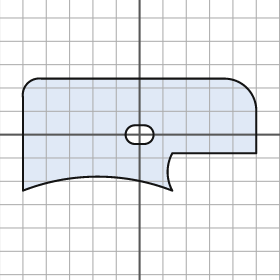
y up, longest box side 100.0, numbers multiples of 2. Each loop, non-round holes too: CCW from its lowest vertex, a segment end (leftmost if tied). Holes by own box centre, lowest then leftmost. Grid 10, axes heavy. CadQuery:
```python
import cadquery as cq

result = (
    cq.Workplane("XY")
    .moveTo(-50.0, -24.0)
    .threePointArc((-18.0, -18.0), (14.0, -24.0))
    .threePointArc((12.0, -16.0), (14.0, -8.0))
    .lineTo(50.0, -8.0)
    .lineTo(50.0, 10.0)
    .threePointArc((46.0, 20.0), (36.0, 24.0))
    .lineTo(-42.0, 24.0)
    .threePointArc((-48.0, 22.0), (-50.0, 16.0))
    .close()
    .moveTo(-2.0, -4.0)
    .lineTo(2.0, -4.0)
    .threePointArc((6.0, 0.0), (2.0, 4.0))
    .lineTo(-2.0, 4.0)
    .threePointArc((-6.0, 0.0), (-2.0, -4.0))
    .close()
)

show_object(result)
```